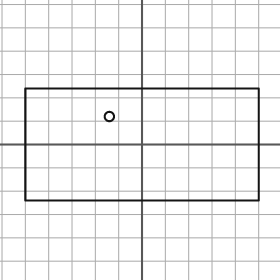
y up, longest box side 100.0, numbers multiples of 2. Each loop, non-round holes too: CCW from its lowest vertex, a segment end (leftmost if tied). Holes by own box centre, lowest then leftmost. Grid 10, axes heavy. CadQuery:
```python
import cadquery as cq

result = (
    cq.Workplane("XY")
    .moveTo(-50.0, -24.0)
    .lineTo(50.0, -24.0)
    .lineTo(50.0, 24.0)
    .lineTo(-50.0, 24.0)
    .close()
    .moveTo(-14.0, 12.0)
    .circle(2.0)
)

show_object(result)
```